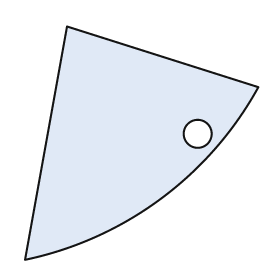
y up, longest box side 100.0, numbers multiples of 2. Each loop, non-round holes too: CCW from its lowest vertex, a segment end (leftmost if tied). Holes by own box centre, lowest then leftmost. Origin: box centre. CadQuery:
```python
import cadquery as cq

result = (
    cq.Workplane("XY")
    .moveTo(-50.0, -50.0)
    .threePointArc((8.0, -24.0), (50.0, 24.0))
    .lineTo(-32.0, 50.0)
    .close()
    .moveTo(24.0, 4.0)
    .circle(6.0)
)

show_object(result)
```